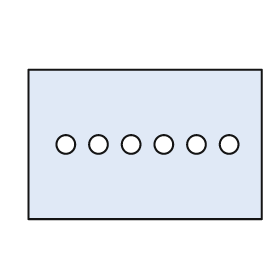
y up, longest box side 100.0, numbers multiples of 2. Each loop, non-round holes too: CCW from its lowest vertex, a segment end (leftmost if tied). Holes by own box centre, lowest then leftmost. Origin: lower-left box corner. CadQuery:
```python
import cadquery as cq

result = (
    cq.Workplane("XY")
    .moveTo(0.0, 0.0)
    .lineTo(100.0, 0.0)
    .lineTo(100.0, 64.0)
    .lineTo(0.0, 64.0)
    .close()
    .moveTo(16.0, 32.0)
    .circle(4.0)
    .moveTo(30.0, 32.0)
    .circle(4.0)
    .moveTo(44.0, 32.0)
    .circle(4.0)
    .moveTo(58.0, 32.0)
    .circle(4.0)
    .moveTo(72.0, 32.0)
    .circle(4.0)
    .moveTo(86.0, 32.0)
    .circle(4.0)
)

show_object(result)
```